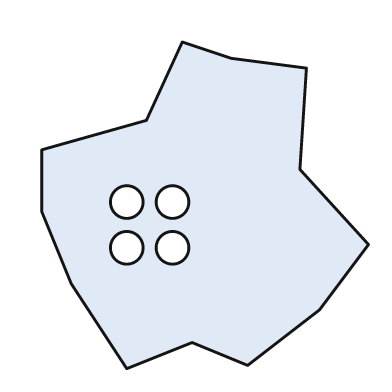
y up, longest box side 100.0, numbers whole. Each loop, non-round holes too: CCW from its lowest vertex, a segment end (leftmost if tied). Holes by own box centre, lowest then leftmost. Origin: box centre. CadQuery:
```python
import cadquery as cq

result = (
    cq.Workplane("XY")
    .moveTo(-24.0, -50.0)
    .lineTo(-4.0, -42.0)
    .lineTo(13.0, -49.0)
    .lineTo(35.0, -32.0)
    .lineTo(50.0, -12.0)
    .lineTo(29.0, 11.0)
    .lineTo(31.0, 42.0)
    .lineTo(8.0, 45.0)
    .lineTo(-7.0, 50.0)
    .lineTo(-18.0, 26.0)
    .lineTo(-50.0, 17.0)
    .lineTo(-50.0, -2.0)
    .lineTo(-41.0, -24.0)
    .close()
    .moveTo(-24.0, -13.0)
    .circle(5.0)
    .moveTo(-10.0, -13.0)
    .circle(5.0)
    .moveTo(-24.0, 1.0)
    .circle(5.0)
    .moveTo(-10.0, 1.0)
    .circle(5.0)
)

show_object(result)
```